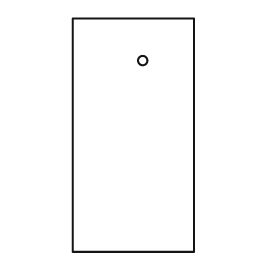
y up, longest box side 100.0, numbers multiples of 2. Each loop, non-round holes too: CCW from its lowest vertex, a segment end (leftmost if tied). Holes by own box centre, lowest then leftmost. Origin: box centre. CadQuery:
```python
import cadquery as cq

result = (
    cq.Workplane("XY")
    .moveTo(-26.0, -50.0)
    .lineTo(26.0, -50.0)
    .lineTo(26.0, 50.0)
    .lineTo(-26.0, 50.0)
    .close()
    .moveTo(4.0, 32.0)
    .circle(2.0)
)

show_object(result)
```